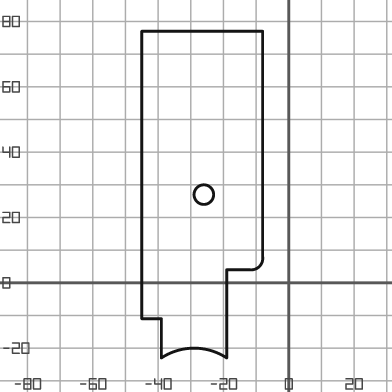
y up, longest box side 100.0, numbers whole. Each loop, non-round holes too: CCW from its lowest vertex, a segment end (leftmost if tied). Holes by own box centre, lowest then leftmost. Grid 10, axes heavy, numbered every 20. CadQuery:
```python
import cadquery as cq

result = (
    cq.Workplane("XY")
    .moveTo(-39.0, -23.0)
    .threePointArc((-29.0, -20.0), (-19.0, -23.0))
    .lineTo(-19.0, 4.0)
    .lineTo(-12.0, 4.0)
    .threePointArc((-9.0, 5.0), (-8.0, 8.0))
    .lineTo(-8.0, 77.0)
    .lineTo(-45.0, 77.0)
    .lineTo(-45.0, -11.0)
    .lineTo(-39.0, -11.0)
    .close()
    .moveTo(-26.0, 27.0)
    .circle(3.0)
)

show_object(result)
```